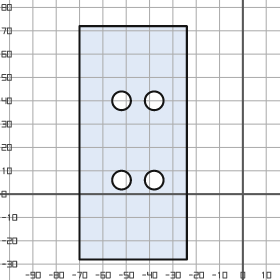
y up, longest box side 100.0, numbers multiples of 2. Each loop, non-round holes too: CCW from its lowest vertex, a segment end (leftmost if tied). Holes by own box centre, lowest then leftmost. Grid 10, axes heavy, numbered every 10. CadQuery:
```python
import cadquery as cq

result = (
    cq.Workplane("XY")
    .moveTo(-70.0, -28.0)
    .lineTo(-24.0, -28.0)
    .lineTo(-24.0, 72.0)
    .lineTo(-70.0, 72.0)
    .close()
    .moveTo(-52.0, 6.0)
    .circle(4.0)
    .moveTo(-38.0, 6.0)
    .circle(4.0)
    .moveTo(-52.0, 40.0)
    .circle(4.0)
    .moveTo(-38.0, 40.0)
    .circle(4.0)
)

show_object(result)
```